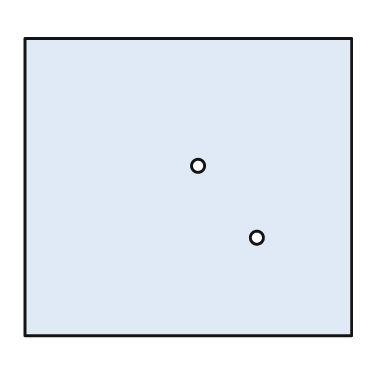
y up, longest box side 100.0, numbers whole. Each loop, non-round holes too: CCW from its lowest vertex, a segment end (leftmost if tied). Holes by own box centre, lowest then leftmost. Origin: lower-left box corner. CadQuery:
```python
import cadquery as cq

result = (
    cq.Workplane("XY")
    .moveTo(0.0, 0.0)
    .lineTo(100.0, 0.0)
    .lineTo(100.0, 91.0)
    .lineTo(0.0, 91.0)
    .close()
    .moveTo(71.0, 30.0)
    .circle(2.0)
    .moveTo(53.0, 52.0)
    .circle(2.0)
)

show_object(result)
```